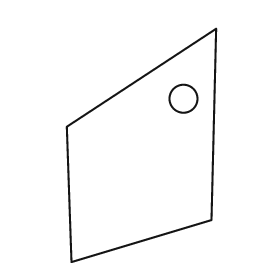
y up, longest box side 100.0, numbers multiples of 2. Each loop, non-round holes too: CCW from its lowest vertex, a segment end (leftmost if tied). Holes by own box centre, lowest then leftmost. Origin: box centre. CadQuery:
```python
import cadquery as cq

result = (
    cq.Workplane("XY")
    .moveTo(-30.0, -50.0)
    .lineTo(30.0, -32.0)
    .lineTo(32.0, 50.0)
    .lineTo(-32.0, 8.0)
    .close()
    .moveTo(18.0, 20.0)
    .circle(6.0)
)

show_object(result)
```